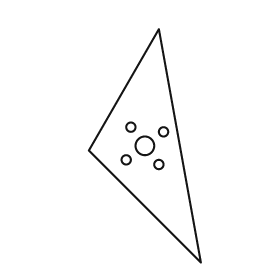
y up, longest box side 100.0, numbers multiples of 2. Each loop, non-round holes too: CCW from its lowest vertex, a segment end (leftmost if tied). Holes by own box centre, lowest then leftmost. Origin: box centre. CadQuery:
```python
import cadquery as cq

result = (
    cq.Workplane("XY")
    .moveTo(24.0, -50.0)
    .lineTo(6.0, 50.0)
    .lineTo(-24.0, -2.0)
    .close()
    .moveTo(6.0, -8.0)
    .circle(2.0)
    .moveTo(-8.0, -6.0)
    .circle(2.0)
    .moveTo(0.0, 0.0)
    .circle(4.0)
    .moveTo(8.0, 6.0)
    .circle(2.0)
    .moveTo(-6.0, 8.0)
    .circle(2.0)
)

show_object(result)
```